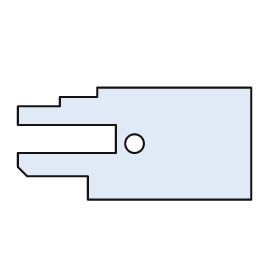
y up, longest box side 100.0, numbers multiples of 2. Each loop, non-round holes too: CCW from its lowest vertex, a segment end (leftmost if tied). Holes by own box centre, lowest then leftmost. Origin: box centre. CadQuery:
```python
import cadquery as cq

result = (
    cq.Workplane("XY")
    .moveTo(-20.0, -24.0)
    .lineTo(50.0, -24.0)
    .lineTo(50.0, 24.0)
    .lineTo(-16.0, 24.0)
    .lineTo(-16.0, 20.0)
    .lineTo(-32.0, 20.0)
    .lineTo(-32.0, 16.0)
    .lineTo(-50.0, 16.0)
    .lineTo(-50.0, 8.0)
    .lineTo(-8.0, 8.0)
    .lineTo(-8.0, -4.0)
    .lineTo(-50.0, -4.0)
    .lineTo(-50.0, -10.0)
    .lineTo(-46.0, -14.0)
    .lineTo(-20.0, -14.0)
    .close()
    .moveTo(0.0, 0.0)
    .circle(4.0)
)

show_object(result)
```